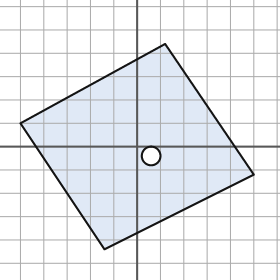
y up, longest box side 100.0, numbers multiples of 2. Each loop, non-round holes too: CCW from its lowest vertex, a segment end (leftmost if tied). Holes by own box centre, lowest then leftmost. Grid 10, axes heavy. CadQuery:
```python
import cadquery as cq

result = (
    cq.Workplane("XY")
    .moveTo(-14.0, -44.0)
    .lineTo(50.0, -12.0)
    .lineTo(12.0, 44.0)
    .lineTo(-50.0, 10.0)
    .close()
    .moveTo(6.0, -4.0)
    .circle(4.0)
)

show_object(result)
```